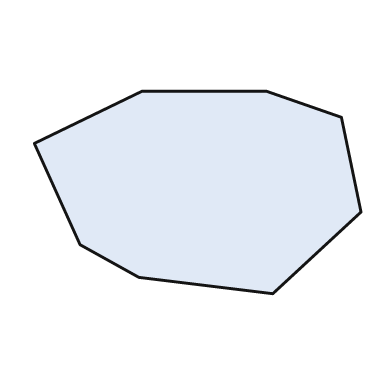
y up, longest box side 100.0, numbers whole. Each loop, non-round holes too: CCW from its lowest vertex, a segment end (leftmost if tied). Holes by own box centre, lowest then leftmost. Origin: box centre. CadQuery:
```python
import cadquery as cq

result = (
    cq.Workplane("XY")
    .moveTo(23.0, -31.0)
    .lineTo(50.0, -6.0)
    .lineTo(44.0, 23.0)
    .lineTo(21.0, 31.0)
    .lineTo(-17.0, 31.0)
    .lineTo(-50.0, 15.0)
    .lineTo(-36.0, -16.0)
    .lineTo(-18.0, -26.0)
    .close()
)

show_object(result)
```